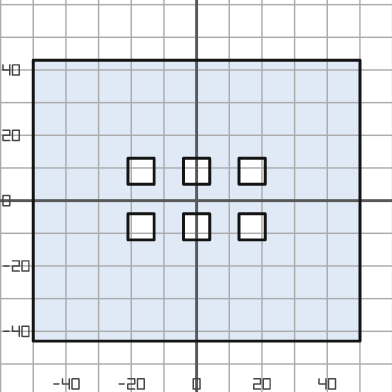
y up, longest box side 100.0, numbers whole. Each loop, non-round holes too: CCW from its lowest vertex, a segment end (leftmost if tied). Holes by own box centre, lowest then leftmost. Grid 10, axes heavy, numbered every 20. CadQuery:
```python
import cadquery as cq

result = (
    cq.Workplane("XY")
    .moveTo(-50.0, -43.0)
    .lineTo(50.0, -43.0)
    .lineTo(50.0, 43.0)
    .lineTo(-50.0, 43.0)
    .close()
    .moveTo(-21.0, -12.0)
    .lineTo(-13.0, -12.0)
    .lineTo(-13.0, -4.0)
    .lineTo(-21.0, -4.0)
    .close()
    .moveTo(-4.0, -12.0)
    .lineTo(4.0, -12.0)
    .lineTo(4.0, -4.0)
    .lineTo(-4.0, -4.0)
    .close()
    .moveTo(13.0, -12.0)
    .lineTo(21.0, -12.0)
    .lineTo(21.0, -4.0)
    .lineTo(13.0, -4.0)
    .close()
    .moveTo(-21.0, 5.0)
    .lineTo(-13.0, 5.0)
    .lineTo(-13.0, 13.0)
    .lineTo(-21.0, 13.0)
    .close()
    .moveTo(-4.0, 5.0)
    .lineTo(4.0, 5.0)
    .lineTo(4.0, 13.0)
    .lineTo(-4.0, 13.0)
    .close()
    .moveTo(13.0, 5.0)
    .lineTo(21.0, 5.0)
    .lineTo(21.0, 13.0)
    .lineTo(13.0, 13.0)
    .close()
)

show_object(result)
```